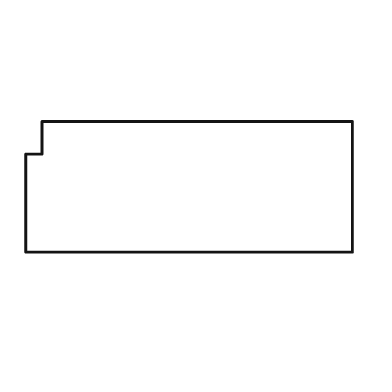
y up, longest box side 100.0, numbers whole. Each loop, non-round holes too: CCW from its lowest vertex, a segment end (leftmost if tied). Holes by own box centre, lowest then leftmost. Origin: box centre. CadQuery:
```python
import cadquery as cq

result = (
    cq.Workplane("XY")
    .moveTo(-50.0, -20.0)
    .lineTo(50.0, -20.0)
    .lineTo(50.0, 20.0)
    .lineTo(-45.0, 20.0)
    .lineTo(-45.0, 10.0)
    .lineTo(-50.0, 10.0)
    .close()
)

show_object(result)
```